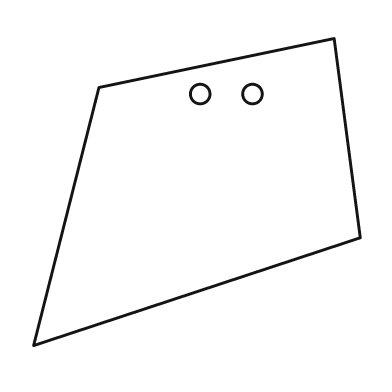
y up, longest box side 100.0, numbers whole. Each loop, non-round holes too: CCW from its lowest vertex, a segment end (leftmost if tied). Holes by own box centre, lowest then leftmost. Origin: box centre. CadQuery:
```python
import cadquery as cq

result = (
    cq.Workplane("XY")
    .moveTo(-50.0, -47.0)
    .lineTo(50.0, -14.0)
    .lineTo(42.0, 47.0)
    .lineTo(-30.0, 32.0)
    .close()
    .moveTo(1.0, 30.0)
    .circle(3.0)
    .moveTo(17.0, 30.0)
    .circle(3.0)
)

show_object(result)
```